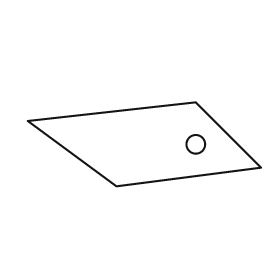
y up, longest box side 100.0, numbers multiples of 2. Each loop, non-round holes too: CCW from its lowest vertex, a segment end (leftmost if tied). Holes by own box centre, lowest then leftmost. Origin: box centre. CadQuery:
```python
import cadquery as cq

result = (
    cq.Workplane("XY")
    .moveTo(-12.0, -18.0)
    .lineTo(50.0, -10.0)
    .lineTo(22.0, 18.0)
    .lineTo(-50.0, 10.0)
    .close()
    .moveTo(22.0, 0.0)
    .circle(4.0)
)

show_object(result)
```